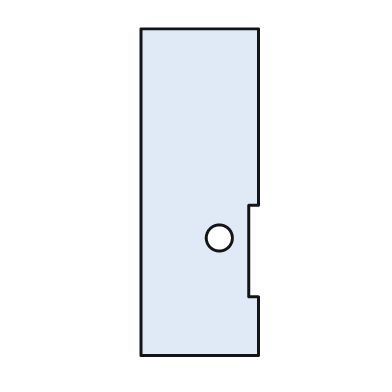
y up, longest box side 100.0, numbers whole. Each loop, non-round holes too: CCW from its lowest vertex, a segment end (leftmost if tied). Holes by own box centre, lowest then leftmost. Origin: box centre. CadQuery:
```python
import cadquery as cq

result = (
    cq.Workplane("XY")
    .moveTo(-18.0, -50.0)
    .lineTo(18.0, -50.0)
    .lineTo(18.0, -32.0)
    .lineTo(15.0, -32.0)
    .lineTo(15.0, -4.0)
    .lineTo(18.0, -4.0)
    .lineTo(18.0, 50.0)
    .lineTo(-18.0, 50.0)
    .close()
    .moveTo(6.0, -14.0)
    .circle(4.0)
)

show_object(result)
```